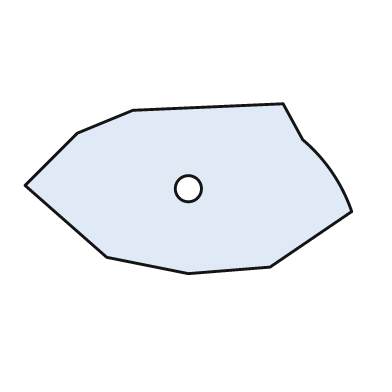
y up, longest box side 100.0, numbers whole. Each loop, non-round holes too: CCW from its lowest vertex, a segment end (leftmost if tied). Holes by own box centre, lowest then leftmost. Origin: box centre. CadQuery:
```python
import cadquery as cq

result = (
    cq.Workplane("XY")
    .moveTo(0.0, -26.0)
    .lineTo(25.0, -24.0)
    .lineTo(50.0, -7.0)
    .threePointArc((44.0, 5.0), (35.0, 15.0))
    .lineTo(29.0, 26.0)
    .lineTo(-17.0, 24.0)
    .lineTo(-34.0, 17.0)
    .lineTo(-50.0, 1.0)
    .lineTo(-25.0, -21.0)
    .close()
    .moveTo(0.0, 0.0)
    .circle(4.0)
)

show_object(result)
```